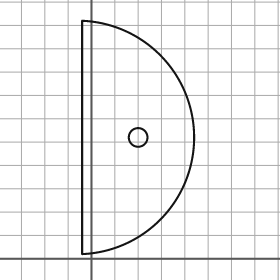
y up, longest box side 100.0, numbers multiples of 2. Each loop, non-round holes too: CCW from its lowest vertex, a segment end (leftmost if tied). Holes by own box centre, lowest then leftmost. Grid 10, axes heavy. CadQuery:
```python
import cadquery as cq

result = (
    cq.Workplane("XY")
    .moveTo(-4.0, 2.0)
    .threePointArc((44.0, 52.0), (-4.0, 102.0))
    .close()
    .moveTo(20.0, 52.0)
    .circle(4.0)
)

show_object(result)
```